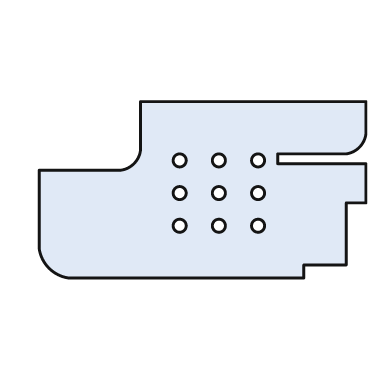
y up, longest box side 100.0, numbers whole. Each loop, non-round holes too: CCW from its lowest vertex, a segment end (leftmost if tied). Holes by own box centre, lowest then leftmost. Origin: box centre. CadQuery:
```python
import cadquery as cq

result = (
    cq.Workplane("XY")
    .moveTo(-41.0, -27.0)
    .lineTo(31.0, -27.0)
    .lineTo(31.0, -23.0)
    .lineTo(44.0, -23.0)
    .lineTo(44.0, -4.0)
    .lineTo(50.0, -4.0)
    .lineTo(50.0, 8.0)
    .lineTo(23.0, 8.0)
    .lineTo(23.0, 11.0)
    .lineTo(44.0, 11.0)
    .threePointArc((48.0, 13.0), (50.0, 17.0))
    .lineTo(50.0, 27.0)
    .lineTo(-19.0, 27.0)
    .lineTo(-19.0, 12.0)
    .threePointArc((-21.0, 8.0), (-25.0, 6.0))
    .lineTo(-50.0, 6.0)
    .lineTo(-50.0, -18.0)
    .threePointArc((-47.0, -24.0), (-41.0, -27.0))
    .close()
    .moveTo(-7.0, -11.0)
    .circle(2.0)
    .moveTo(5.0, -11.0)
    .circle(2.0)
    .moveTo(17.0, -11.0)
    .circle(2.0)
    .moveTo(-7.0, -1.0)
    .circle(2.0)
    .moveTo(5.0, -1.0)
    .circle(2.0)
    .moveTo(17.0, -1.0)
    .circle(2.0)
    .moveTo(-7.0, 9.0)
    .circle(2.0)
    .moveTo(5.0, 9.0)
    .circle(2.0)
    .moveTo(17.0, 9.0)
    .circle(2.0)
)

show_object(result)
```